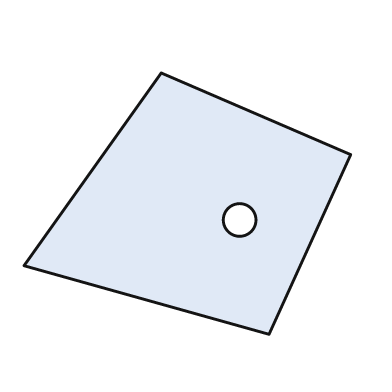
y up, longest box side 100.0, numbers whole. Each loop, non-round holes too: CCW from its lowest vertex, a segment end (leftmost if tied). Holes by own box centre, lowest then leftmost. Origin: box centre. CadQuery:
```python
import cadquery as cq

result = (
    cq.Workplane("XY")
    .moveTo(25.0, -40.0)
    .lineTo(50.0, 15.0)
    .lineTo(-8.0, 40.0)
    .lineTo(-50.0, -19.0)
    .close()
    .moveTo(16.0, -5.0)
    .circle(5.0)
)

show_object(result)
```